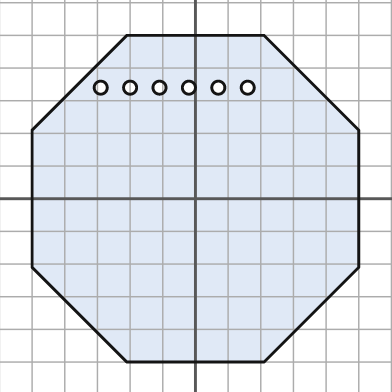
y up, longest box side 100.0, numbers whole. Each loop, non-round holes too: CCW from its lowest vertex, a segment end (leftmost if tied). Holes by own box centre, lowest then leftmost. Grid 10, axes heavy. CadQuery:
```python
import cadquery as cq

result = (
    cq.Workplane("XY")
    .moveTo(-21.0, -50.0)
    .lineTo(21.0, -50.0)
    .lineTo(50.0, -21.0)
    .lineTo(50.0, 21.0)
    .lineTo(21.0, 50.0)
    .lineTo(-21.0, 50.0)
    .lineTo(-50.0, 21.0)
    .lineTo(-50.0, -21.0)
    .close()
    .moveTo(-29.0, 34.0)
    .circle(2.0)
    .moveTo(-20.0, 34.0)
    .circle(2.0)
    .moveTo(-11.0, 34.0)
    .circle(2.0)
    .moveTo(-2.0, 34.0)
    .circle(2.0)
    .moveTo(7.0, 34.0)
    .circle(2.0)
    .moveTo(16.0, 34.0)
    .circle(2.0)
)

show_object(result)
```